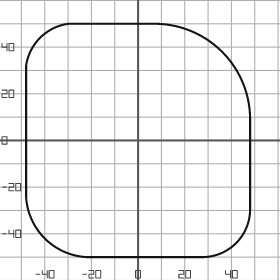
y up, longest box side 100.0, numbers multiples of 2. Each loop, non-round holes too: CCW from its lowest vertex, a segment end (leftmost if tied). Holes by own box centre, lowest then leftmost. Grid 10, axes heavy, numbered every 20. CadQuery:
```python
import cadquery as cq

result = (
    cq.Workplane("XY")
    .moveTo(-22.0, -50.0)
    .lineTo(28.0, -50.0)
    .threePointArc((42.0, -44.0), (48.0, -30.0))
    .lineTo(48.0, 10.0)
    .threePointArc((36.0, 38.0), (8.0, 50.0))
    .lineTo(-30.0, 50.0)
    .threePointArc((-42.0, 44.0), (-48.0, 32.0))
    .lineTo(-48.0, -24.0)
    .threePointArc((-40.0, -42.0), (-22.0, -50.0))
    .close()
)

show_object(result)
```